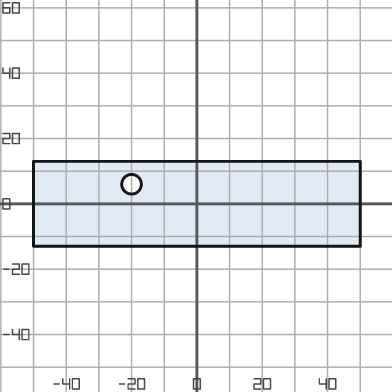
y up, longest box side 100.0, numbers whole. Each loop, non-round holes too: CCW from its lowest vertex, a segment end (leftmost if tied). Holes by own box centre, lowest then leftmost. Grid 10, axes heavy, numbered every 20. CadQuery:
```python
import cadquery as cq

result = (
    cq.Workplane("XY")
    .moveTo(-50.0, -13.0)
    .lineTo(50.0, -13.0)
    .lineTo(50.0, 13.0)
    .lineTo(-50.0, 13.0)
    .close()
    .moveTo(-20.0, 6.0)
    .circle(3.0)
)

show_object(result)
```